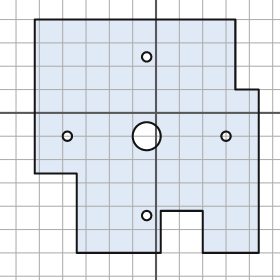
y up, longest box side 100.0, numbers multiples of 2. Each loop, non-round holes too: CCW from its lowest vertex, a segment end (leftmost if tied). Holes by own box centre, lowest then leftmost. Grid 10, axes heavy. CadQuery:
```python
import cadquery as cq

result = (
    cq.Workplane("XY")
    .moveTo(-34.0, -60.0)
    .lineTo(2.0, -60.0)
    .lineTo(2.0, -42.0)
    .lineTo(20.0, -42.0)
    .lineTo(20.0, -60.0)
    .lineTo(44.0, -60.0)
    .lineTo(44.0, 10.0)
    .lineTo(34.0, 10.0)
    .lineTo(34.0, 40.0)
    .lineTo(-52.0, 40.0)
    .lineTo(-52.0, -26.0)
    .lineTo(-34.0, -26.0)
    .close()
    .moveTo(-4.0, -44.0)
    .circle(2.0)
    .moveTo(-38.0, -10.0)
    .circle(2.0)
    .moveTo(-4.0, -10.0)
    .circle(6.0)
    .moveTo(30.0, -10.0)
    .circle(2.0)
    .moveTo(-4.0, 24.0)
    .circle(2.0)
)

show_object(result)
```